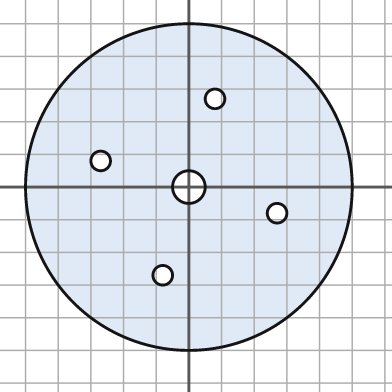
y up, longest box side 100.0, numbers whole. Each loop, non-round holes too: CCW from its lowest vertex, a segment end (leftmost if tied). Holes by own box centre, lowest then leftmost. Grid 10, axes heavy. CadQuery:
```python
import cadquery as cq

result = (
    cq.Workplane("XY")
    .moveTo(0.0, 0.0)
    .circle(50.0)
    .moveTo(-8.0, -27.0)
    .circle(3.0)
    .moveTo(27.0, -8.0)
    .circle(3.0)
    .moveTo(0.0, 0.0)
    .circle(5.0)
    .moveTo(-27.0, 8.0)
    .circle(3.0)
    .moveTo(8.0, 27.0)
    .circle(3.0)
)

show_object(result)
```